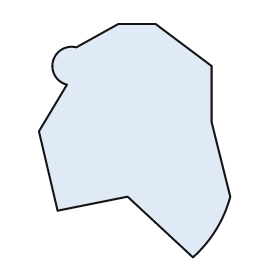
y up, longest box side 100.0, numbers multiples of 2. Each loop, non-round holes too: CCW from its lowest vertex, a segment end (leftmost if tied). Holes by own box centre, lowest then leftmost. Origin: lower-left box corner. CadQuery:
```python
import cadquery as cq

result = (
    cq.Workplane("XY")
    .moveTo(66.0, 0.0)
    .threePointArc((76.0, 12.0), (82.0, 26.0))
    .lineTo(74.0, 58.0)
    .lineTo(74.0, 82.0)
    .lineTo(50.0, 100.0)
    .lineTo(34.0, 100.0)
    .lineTo(16.0, 90.0)
    .threePointArc((6.0, 84.0), (12.0, 74.0))
    .lineTo(0.0, 54.0)
    .lineTo(8.0, 20.0)
    .lineTo(38.0, 26.0)
    .close()
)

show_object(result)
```